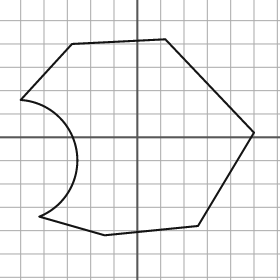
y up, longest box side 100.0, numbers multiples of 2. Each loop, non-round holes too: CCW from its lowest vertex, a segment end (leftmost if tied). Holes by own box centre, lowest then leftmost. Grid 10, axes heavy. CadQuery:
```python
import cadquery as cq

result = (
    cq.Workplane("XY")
    .moveTo(-14.0, -42.0)
    .lineTo(26.0, -38.0)
    .lineTo(50.0, 2.0)
    .lineTo(12.0, 42.0)
    .lineTo(-28.0, 40.0)
    .lineTo(-50.0, 16.0)
    .threePointArc((-26.0, -6.0), (-42.0, -34.0))
    .close()
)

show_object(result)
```